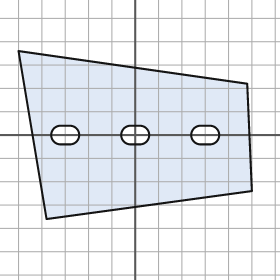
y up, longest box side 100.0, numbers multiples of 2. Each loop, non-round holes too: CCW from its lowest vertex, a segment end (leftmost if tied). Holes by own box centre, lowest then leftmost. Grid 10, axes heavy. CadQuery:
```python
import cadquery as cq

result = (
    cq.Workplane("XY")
    .moveTo(-38.0, -36.0)
    .lineTo(50.0, -24.0)
    .lineTo(48.0, 22.0)
    .lineTo(-50.0, 36.0)
    .close()
    .moveTo(-32.0, -4.0)
    .lineTo(-28.0, -4.0)
    .threePointArc((-24.0, 0.0), (-28.0, 4.0))
    .lineTo(-32.0, 4.0)
    .threePointArc((-36.0, 0.0), (-32.0, -4.0))
    .close()
    .moveTo(-2.0, -4.0)
    .lineTo(2.0, -4.0)
    .threePointArc((6.0, 0.0), (2.0, 4.0))
    .lineTo(-2.0, 4.0)
    .threePointArc((-6.0, 0.0), (-2.0, -4.0))
    .close()
    .moveTo(28.0, -4.0)
    .lineTo(32.0, -4.0)
    .threePointArc((36.0, 0.0), (32.0, 4.0))
    .lineTo(28.0, 4.0)
    .threePointArc((24.0, 0.0), (28.0, -4.0))
    .close()
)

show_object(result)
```